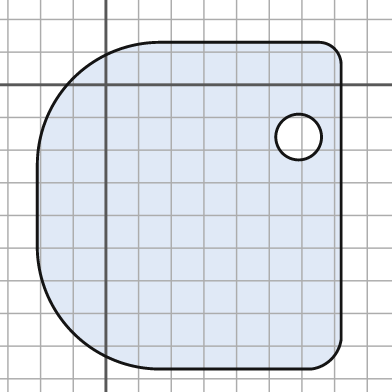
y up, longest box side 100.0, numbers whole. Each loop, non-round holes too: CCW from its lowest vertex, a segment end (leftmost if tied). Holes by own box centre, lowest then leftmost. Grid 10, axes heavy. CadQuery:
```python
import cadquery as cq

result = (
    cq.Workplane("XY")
    .moveTo(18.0, -87.0)
    .lineTo(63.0, -87.0)
    .threePointArc((69.0, -84.0), (72.0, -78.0))
    .lineTo(72.0, 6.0)
    .threePointArc((70.0, 11.0), (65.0, 13.0))
    .lineTo(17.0, 13.0)
    .threePointArc((-10.0, 2.0), (-21.0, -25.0))
    .lineTo(-21.0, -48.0)
    .threePointArc((-10.0, -76.0), (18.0, -87.0))
    .close()
    .moveTo(59.0, -16.0)
    .circle(7.0)
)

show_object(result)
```